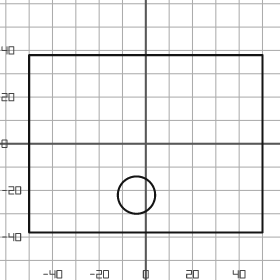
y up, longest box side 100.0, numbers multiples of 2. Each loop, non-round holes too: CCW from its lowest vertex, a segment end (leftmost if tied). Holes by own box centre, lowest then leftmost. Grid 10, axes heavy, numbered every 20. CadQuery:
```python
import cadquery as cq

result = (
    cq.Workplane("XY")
    .moveTo(-50.0, -38.0)
    .lineTo(50.0, -38.0)
    .lineTo(50.0, 38.0)
    .lineTo(-50.0, 38.0)
    .close()
    .moveTo(-4.0, -22.0)
    .circle(8.0)
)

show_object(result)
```